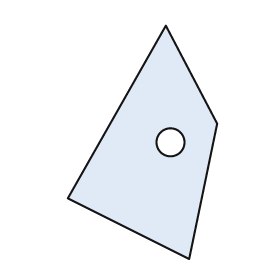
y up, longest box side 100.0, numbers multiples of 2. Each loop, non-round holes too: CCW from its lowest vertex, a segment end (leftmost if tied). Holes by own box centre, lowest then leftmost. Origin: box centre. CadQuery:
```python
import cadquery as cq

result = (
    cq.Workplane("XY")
    .moveTo(20.0, -50.0)
    .lineTo(32.0, 8.0)
    .lineTo(10.0, 50.0)
    .lineTo(-32.0, -24.0)
    .close()
    .moveTo(12.0, 0.0)
    .circle(6.0)
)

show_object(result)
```